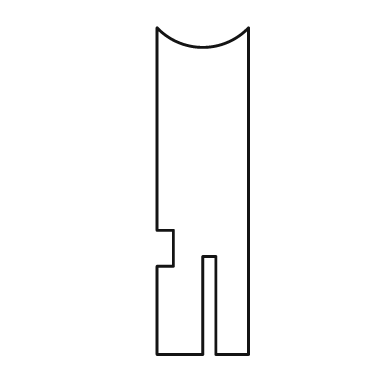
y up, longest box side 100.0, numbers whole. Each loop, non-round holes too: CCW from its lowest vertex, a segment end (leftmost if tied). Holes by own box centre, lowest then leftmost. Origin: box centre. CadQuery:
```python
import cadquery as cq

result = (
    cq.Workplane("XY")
    .moveTo(-14.0, -50.0)
    .lineTo(0.0, -50.0)
    .lineTo(0.0, -20.0)
    .lineTo(4.0, -20.0)
    .lineTo(4.0, -50.0)
    .lineTo(14.0, -50.0)
    .lineTo(14.0, 50.0)
    .threePointArc((0.0, 44.0), (-14.0, 50.0))
    .lineTo(-14.0, -12.0)
    .lineTo(-9.0, -12.0)
    .lineTo(-9.0, -23.0)
    .lineTo(-14.0, -23.0)
    .close()
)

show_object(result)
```